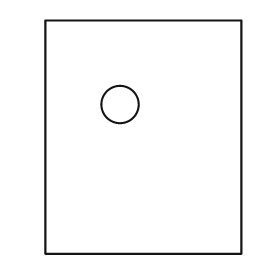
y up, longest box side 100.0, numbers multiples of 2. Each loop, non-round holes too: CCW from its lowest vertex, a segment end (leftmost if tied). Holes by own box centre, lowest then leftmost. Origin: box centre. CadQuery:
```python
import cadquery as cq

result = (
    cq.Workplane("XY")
    .moveTo(-42.0, -50.0)
    .lineTo(42.0, -50.0)
    .lineTo(42.0, 50.0)
    .lineTo(-42.0, 50.0)
    .close()
    .moveTo(-10.0, 14.0)
    .circle(8.0)
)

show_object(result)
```